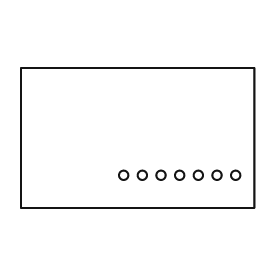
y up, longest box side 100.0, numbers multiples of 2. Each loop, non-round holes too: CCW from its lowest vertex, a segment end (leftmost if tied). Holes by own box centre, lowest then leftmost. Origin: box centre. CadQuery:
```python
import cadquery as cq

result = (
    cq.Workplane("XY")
    .moveTo(-50.0, -30.0)
    .lineTo(50.0, -30.0)
    .lineTo(50.0, 30.0)
    .lineTo(-50.0, 30.0)
    .close()
    .moveTo(-6.0, -16.0)
    .circle(2.0)
    .moveTo(2.0, -16.0)
    .circle(2.0)
    .moveTo(10.0, -16.0)
    .circle(2.0)
    .moveTo(18.0, -16.0)
    .circle(2.0)
    .moveTo(26.0, -16.0)
    .circle(2.0)
    .moveTo(34.0, -16.0)
    .circle(2.0)
    .moveTo(42.0, -16.0)
    .circle(2.0)
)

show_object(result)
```